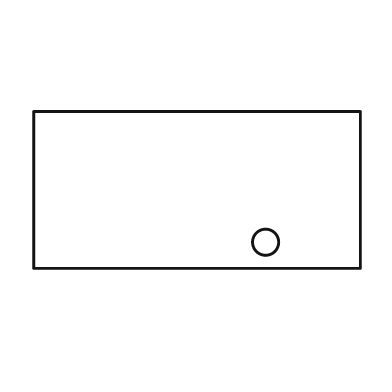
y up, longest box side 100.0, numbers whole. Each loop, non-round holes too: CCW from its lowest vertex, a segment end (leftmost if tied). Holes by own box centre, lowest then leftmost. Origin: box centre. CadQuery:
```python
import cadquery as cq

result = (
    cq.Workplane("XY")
    .moveTo(-50.0, -24.0)
    .lineTo(50.0, -24.0)
    .lineTo(50.0, 24.0)
    .lineTo(-50.0, 24.0)
    .close()
    .moveTo(21.0, -16.0)
    .circle(4.0)
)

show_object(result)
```